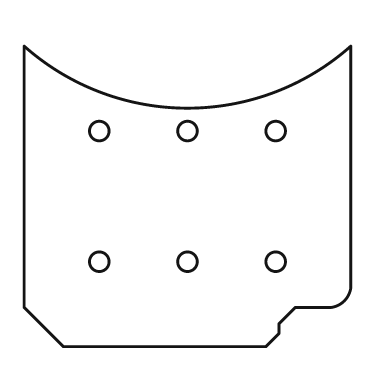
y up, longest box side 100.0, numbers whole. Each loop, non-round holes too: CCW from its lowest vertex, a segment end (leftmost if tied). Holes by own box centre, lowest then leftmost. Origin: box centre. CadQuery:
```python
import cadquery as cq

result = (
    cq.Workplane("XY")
    .moveTo(-38.0, -46.0)
    .lineTo(24.0, -46.0)
    .lineTo(28.0, -42.0)
    .lineTo(28.0, -39.0)
    .lineTo(33.0, -34.0)
    .lineTo(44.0, -34.0)
    .threePointArc((48.0, -32.0), (50.0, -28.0))
    .lineTo(50.0, 46.0)
    .threePointArc((0.0, 27.0), (-50.0, 46.0))
    .lineTo(-50.0, -34.0)
    .close()
    .moveTo(-27.0, -20.0)
    .circle(3.0)
    .moveTo(0.0, -20.0)
    .circle(3.0)
    .moveTo(27.0, -20.0)
    .circle(3.0)
    .moveTo(-27.0, 20.0)
    .circle(3.0)
    .moveTo(0.0, 20.0)
    .circle(3.0)
    .moveTo(27.0, 20.0)
    .circle(3.0)
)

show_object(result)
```